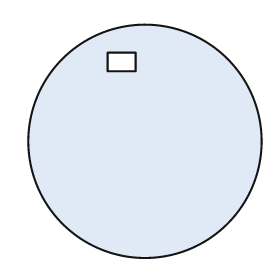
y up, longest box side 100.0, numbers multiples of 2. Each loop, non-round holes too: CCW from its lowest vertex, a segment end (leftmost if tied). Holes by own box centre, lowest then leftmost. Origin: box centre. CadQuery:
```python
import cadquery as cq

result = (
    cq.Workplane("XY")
    .moveTo(0.0, 0.0)
    .circle(50.0)
    .moveTo(-16.0, 30.0)
    .lineTo(-4.0, 30.0)
    .lineTo(-4.0, 38.0)
    .lineTo(-16.0, 38.0)
    .close()
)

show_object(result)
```